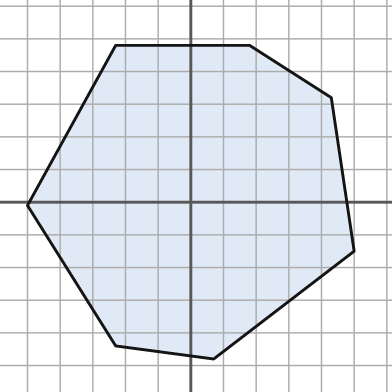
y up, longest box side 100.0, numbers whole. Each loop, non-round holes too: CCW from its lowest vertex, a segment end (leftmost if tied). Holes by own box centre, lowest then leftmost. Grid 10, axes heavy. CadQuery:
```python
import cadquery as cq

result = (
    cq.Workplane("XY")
    .moveTo(7.0, -48.0)
    .lineTo(50.0, -15.0)
    .lineTo(43.0, 32.0)
    .lineTo(18.0, 48.0)
    .lineTo(-23.0, 48.0)
    .lineTo(-50.0, -1.0)
    .lineTo(-23.0, -44.0)
    .close()
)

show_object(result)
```